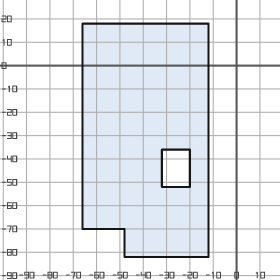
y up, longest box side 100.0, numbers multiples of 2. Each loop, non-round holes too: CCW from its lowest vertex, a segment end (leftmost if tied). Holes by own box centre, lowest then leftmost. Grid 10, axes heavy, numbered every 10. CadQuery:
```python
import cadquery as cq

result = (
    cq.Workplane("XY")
    .moveTo(-48.0, -82.0)
    .lineTo(-12.0, -82.0)
    .lineTo(-12.0, 18.0)
    .lineTo(-66.0, 18.0)
    .lineTo(-66.0, -70.0)
    .lineTo(-48.0, -70.0)
    .close()
    .moveTo(-32.0, -52.0)
    .lineTo(-20.0, -52.0)
    .lineTo(-20.0, -36.0)
    .lineTo(-32.0, -36.0)
    .close()
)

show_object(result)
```